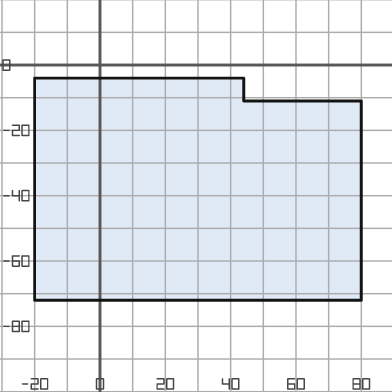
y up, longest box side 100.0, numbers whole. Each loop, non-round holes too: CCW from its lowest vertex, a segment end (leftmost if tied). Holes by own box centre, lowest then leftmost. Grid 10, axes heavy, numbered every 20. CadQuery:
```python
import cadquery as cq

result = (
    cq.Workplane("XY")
    .moveTo(-20.0, -72.0)
    .lineTo(80.0, -72.0)
    .lineTo(80.0, -11.0)
    .lineTo(44.0, -11.0)
    .lineTo(44.0, -4.0)
    .lineTo(-20.0, -4.0)
    .close()
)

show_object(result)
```